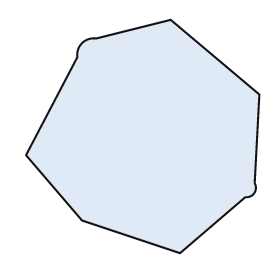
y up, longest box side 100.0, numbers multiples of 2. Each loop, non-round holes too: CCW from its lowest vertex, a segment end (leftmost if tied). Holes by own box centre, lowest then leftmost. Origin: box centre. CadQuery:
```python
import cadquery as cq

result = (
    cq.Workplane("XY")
    .moveTo(16.0, -50.0)
    .lineTo(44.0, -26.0)
    .threePointArc((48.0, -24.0), (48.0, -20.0))
    .lineTo(50.0, 18.0)
    .lineTo(12.0, 50.0)
    .lineTo(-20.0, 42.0)
    .threePointArc((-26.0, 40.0), (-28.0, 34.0))
    .lineTo(-50.0, -8.0)
    .lineTo(-26.0, -36.0)
    .close()
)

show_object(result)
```